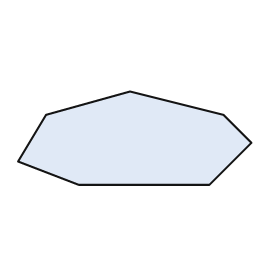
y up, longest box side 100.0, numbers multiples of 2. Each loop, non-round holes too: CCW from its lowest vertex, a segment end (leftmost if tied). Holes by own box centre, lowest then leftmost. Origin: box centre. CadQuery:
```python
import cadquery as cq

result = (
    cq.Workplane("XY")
    .moveTo(-24.0, -20.0)
    .lineTo(32.0, -20.0)
    .lineTo(50.0, -2.0)
    .lineTo(38.0, 10.0)
    .lineTo(-2.0, 20.0)
    .lineTo(-38.0, 10.0)
    .lineTo(-50.0, -10.0)
    .close()
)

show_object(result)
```